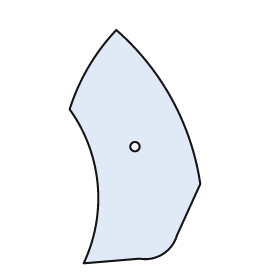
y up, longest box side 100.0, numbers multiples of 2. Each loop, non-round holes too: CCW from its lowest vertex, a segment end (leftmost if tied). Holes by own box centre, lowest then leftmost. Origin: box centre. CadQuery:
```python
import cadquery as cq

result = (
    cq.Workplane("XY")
    .moveTo(-22.0, -50.0)
    .lineTo(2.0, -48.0)
    .threePointArc((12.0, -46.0), (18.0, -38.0))
    .lineTo(28.0, -16.0)
    .threePointArc((16.0, 20.0), (-8.0, 50.0))
    .threePointArc((-20.0, 34.0), (-28.0, 16.0))
    .threePointArc((-16.0, -16.0), (-22.0, -50.0))
    .close()
    .moveTo(0.0, 0.0)
    .circle(2.0)
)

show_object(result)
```